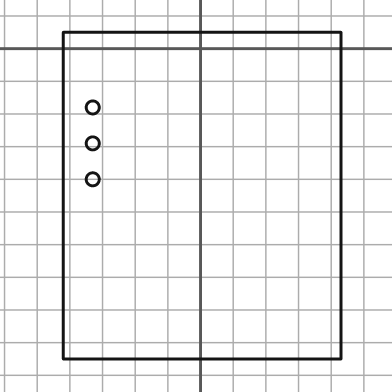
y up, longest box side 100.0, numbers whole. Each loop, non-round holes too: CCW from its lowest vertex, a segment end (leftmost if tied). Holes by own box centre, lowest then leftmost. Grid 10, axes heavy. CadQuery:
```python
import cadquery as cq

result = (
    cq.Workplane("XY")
    .moveTo(-42.0, -95.0)
    .lineTo(43.0, -95.0)
    .lineTo(43.0, 5.0)
    .lineTo(-42.0, 5.0)
    .close()
    .moveTo(-33.0, -40.0)
    .circle(2.0)
    .moveTo(-33.0, -29.0)
    .circle(2.0)
    .moveTo(-33.0, -18.0)
    .circle(2.0)
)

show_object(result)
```